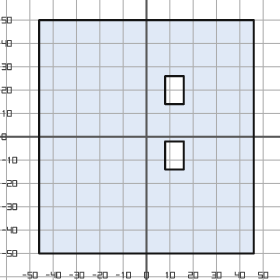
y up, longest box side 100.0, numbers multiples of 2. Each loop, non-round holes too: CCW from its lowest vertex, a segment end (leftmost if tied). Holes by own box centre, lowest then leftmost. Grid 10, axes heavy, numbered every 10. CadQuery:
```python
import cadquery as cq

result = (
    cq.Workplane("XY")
    .moveTo(-46.0, -50.0)
    .lineTo(46.0, -50.0)
    .lineTo(46.0, 50.0)
    .lineTo(-46.0, 50.0)
    .close()
    .moveTo(8.0, -14.0)
    .lineTo(16.0, -14.0)
    .lineTo(16.0, -2.0)
    .lineTo(8.0, -2.0)
    .close()
    .moveTo(8.0, 14.0)
    .lineTo(16.0, 14.0)
    .lineTo(16.0, 26.0)
    .lineTo(8.0, 26.0)
    .close()
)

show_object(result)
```